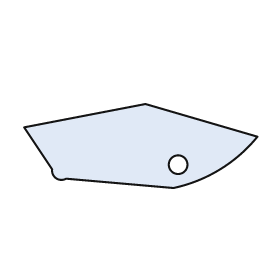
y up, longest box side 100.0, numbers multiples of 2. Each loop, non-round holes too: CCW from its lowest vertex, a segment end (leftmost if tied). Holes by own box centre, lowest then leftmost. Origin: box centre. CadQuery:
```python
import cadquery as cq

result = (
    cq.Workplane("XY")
    .moveTo(14.0, -18.0)
    .threePointArc((34.0, -10.0), (50.0, 4.0))
    .lineTo(2.0, 18.0)
    .lineTo(-50.0, 8.0)
    .lineTo(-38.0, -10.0)
    .threePointArc((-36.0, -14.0), (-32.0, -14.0))
    .close()
    .moveTo(16.0, -8.0)
    .circle(4.0)
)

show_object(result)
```